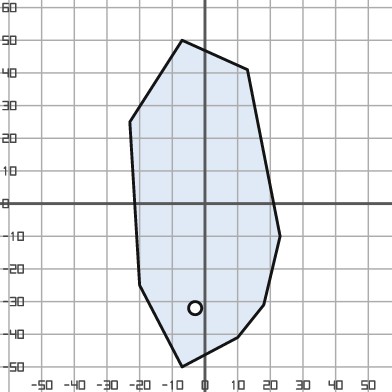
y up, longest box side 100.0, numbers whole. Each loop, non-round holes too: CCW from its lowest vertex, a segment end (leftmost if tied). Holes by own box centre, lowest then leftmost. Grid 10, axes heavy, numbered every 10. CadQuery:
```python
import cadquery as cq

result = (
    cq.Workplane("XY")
    .moveTo(-7.0, -50.0)
    .lineTo(10.0, -41.0)
    .lineTo(18.0, -31.0)
    .lineTo(23.0, -10.0)
    .lineTo(13.0, 41.0)
    .lineTo(-7.0, 50.0)
    .lineTo(-23.0, 25.0)
    .lineTo(-20.0, -25.0)
    .close()
    .moveTo(-3.0, -32.0)
    .circle(2.0)
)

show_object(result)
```